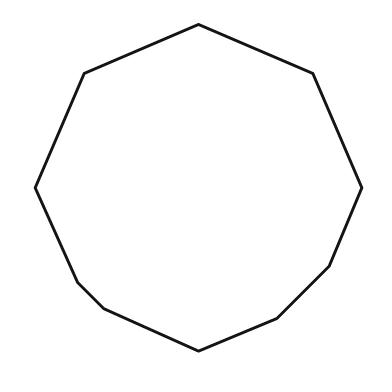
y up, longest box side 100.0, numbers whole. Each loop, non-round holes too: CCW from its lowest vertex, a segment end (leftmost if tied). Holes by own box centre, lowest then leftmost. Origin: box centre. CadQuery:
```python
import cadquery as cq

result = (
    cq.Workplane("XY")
    .moveTo(0.0, -50.0)
    .lineTo(24.0, -40.0)
    .lineTo(40.0, -24.0)
    .lineTo(50.0, 0.0)
    .lineTo(35.0, 35.0)
    .lineTo(0.0, 50.0)
    .lineTo(-35.0, 35.0)
    .lineTo(-50.0, 0.0)
    .lineTo(-37.0, -29.0)
    .lineTo(-29.0, -37.0)
    .close()
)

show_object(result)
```